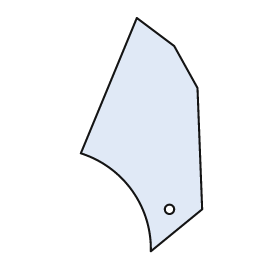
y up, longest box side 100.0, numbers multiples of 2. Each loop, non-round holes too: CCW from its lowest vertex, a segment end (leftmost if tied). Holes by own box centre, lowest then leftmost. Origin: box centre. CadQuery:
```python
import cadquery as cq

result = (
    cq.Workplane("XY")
    .moveTo(4.0, -50.0)
    .lineTo(26.0, -32.0)
    .lineTo(24.0, 20.0)
    .lineTo(14.0, 38.0)
    .lineTo(-2.0, 50.0)
    .lineTo(-26.0, -8.0)
    .threePointArc((-4.0, -24.0), (4.0, -50.0))
    .close()
    .moveTo(12.0, -32.0)
    .circle(2.0)
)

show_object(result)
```